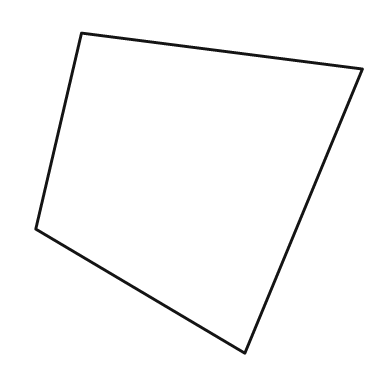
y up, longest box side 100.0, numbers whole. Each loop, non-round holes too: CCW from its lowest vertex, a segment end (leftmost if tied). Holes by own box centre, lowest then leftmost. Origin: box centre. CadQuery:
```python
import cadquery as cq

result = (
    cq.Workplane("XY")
    .moveTo(14.0, -49.0)
    .lineTo(50.0, 38.0)
    .lineTo(-36.0, 49.0)
    .lineTo(-50.0, -11.0)
    .close()
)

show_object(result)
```